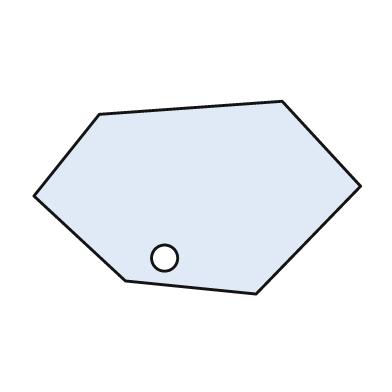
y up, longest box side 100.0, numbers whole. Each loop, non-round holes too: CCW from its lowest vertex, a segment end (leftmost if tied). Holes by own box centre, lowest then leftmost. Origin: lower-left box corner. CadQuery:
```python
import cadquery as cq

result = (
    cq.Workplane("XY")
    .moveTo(68.0, 0.0)
    .lineTo(100.0, 33.0)
    .lineTo(76.0, 59.0)
    .lineTo(20.0, 55.0)
    .lineTo(0.0, 30.0)
    .lineTo(28.0, 4.0)
    .close()
    .moveTo(40.0, 11.0)
    .circle(4.0)
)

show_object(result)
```